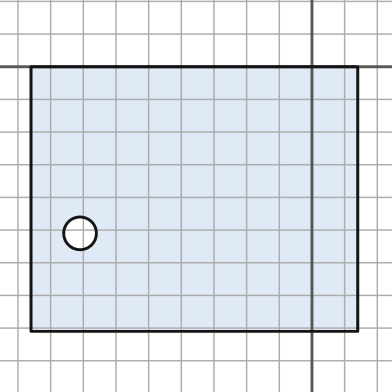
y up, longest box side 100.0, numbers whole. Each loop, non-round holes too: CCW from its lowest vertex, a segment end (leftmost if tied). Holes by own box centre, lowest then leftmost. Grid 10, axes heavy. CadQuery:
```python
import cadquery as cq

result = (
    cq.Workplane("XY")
    .moveTo(-86.0, -81.0)
    .lineTo(14.0, -81.0)
    .lineTo(14.0, 0.0)
    .lineTo(-86.0, 0.0)
    .close()
    .moveTo(-71.0, -51.0)
    .circle(5.0)
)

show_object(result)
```